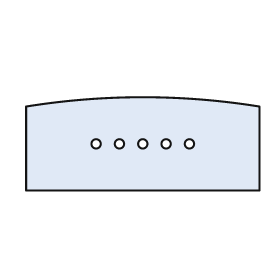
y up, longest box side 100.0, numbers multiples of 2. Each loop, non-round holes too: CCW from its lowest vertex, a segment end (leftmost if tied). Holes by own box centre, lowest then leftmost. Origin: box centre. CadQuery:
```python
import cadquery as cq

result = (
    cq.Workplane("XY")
    .moveTo(-50.0, -20.0)
    .lineTo(50.0, -20.0)
    .lineTo(50.0, 16.0)
    .threePointArc((0.0, 20.0), (-50.0, 16.0))
    .close()
    .moveTo(-20.0, 0.0)
    .circle(2.0)
    .moveTo(-10.0, 0.0)
    .circle(2.0)
    .moveTo(0.0, 0.0)
    .circle(2.0)
    .moveTo(10.0, 0.0)
    .circle(2.0)
    .moveTo(20.0, 0.0)
    .circle(2.0)
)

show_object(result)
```